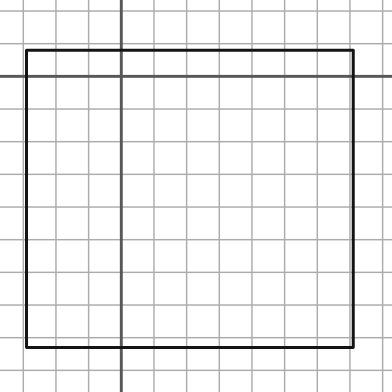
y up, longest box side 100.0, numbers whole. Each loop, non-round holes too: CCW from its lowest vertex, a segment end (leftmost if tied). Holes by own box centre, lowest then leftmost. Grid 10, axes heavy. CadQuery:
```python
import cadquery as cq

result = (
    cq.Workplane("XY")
    .moveTo(-29.0, -83.0)
    .lineTo(71.0, -83.0)
    .lineTo(71.0, 8.0)
    .lineTo(-29.0, 8.0)
    .close()
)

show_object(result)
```